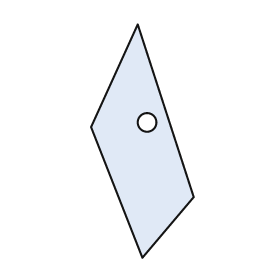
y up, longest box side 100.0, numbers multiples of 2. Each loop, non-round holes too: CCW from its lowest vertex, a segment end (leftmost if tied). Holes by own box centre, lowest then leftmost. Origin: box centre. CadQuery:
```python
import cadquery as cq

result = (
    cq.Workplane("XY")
    .moveTo(0.0, -50.0)
    .lineTo(22.0, -24.0)
    .lineTo(-2.0, 50.0)
    .lineTo(-22.0, 6.0)
    .close()
    .moveTo(2.0, 8.0)
    .circle(4.0)
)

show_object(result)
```